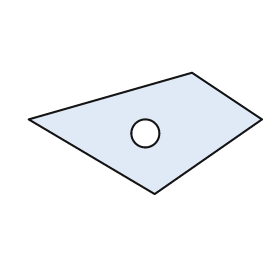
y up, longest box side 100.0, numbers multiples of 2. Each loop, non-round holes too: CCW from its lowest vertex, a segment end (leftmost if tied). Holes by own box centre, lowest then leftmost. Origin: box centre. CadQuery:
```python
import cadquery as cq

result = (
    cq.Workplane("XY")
    .moveTo(4.0, -26.0)
    .lineTo(50.0, 6.0)
    .lineTo(20.0, 26.0)
    .lineTo(-50.0, 6.0)
    .close()
    .moveTo(0.0, 0.0)
    .circle(6.0)
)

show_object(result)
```